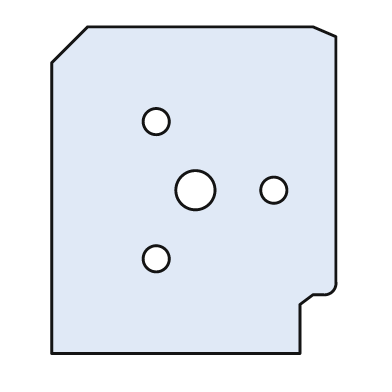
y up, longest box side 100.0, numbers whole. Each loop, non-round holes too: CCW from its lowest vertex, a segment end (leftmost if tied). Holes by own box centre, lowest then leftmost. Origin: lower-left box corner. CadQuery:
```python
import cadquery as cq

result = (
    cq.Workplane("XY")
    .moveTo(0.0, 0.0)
    .lineTo(76.0, 0.0)
    .lineTo(76.0, 15.0)
    .lineTo(80.0, 18.0)
    .lineTo(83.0, 18.0)
    .threePointArc((86.0, 19.0), (87.0, 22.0))
    .lineTo(87.0, 97.0)
    .lineTo(80.0, 100.0)
    .lineTo(11.0, 100.0)
    .lineTo(0.0, 89.0)
    .close()
    .moveTo(32.0, 29.0)
    .circle(4.0)
    .moveTo(44.0, 50.0)
    .circle(6.0)
    .moveTo(68.0, 50.0)
    .circle(4.0)
    .moveTo(32.0, 71.0)
    .circle(4.0)
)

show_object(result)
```